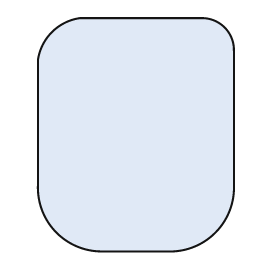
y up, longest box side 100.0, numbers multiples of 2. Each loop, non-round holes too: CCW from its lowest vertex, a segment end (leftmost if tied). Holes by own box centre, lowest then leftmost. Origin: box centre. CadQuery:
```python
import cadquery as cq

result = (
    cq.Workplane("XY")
    .moveTo(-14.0, -50.0)
    .lineTo(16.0, -50.0)
    .threePointArc((34.0, -42.0), (42.0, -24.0))
    .lineTo(42.0, 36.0)
    .threePointArc((38.0, 46.0), (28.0, 50.0))
    .lineTo(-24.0, 50.0)
    .threePointArc((-36.0, 44.0), (-42.0, 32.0))
    .lineTo(-42.0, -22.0)
    .threePointArc((-34.0, -42.0), (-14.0, -50.0))
    .close()
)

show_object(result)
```